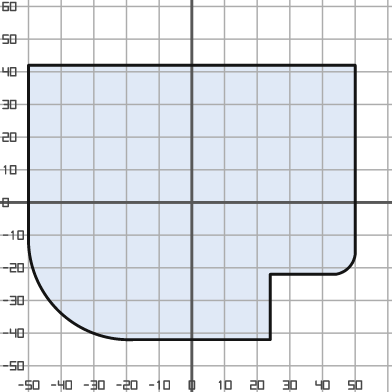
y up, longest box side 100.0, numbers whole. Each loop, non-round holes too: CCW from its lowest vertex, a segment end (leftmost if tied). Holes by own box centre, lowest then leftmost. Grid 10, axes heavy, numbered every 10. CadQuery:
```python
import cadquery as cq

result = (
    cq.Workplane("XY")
    .moveTo(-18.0, -42.0)
    .lineTo(24.0, -42.0)
    .lineTo(24.0, -22.0)
    .lineTo(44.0, -22.0)
    .threePointArc((48.0, -20.0), (50.0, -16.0))
    .lineTo(50.0, 42.0)
    .lineTo(-50.0, 42.0)
    .lineTo(-50.0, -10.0)
    .threePointArc((-41.0, -33.0), (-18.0, -42.0))
    .close()
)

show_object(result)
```